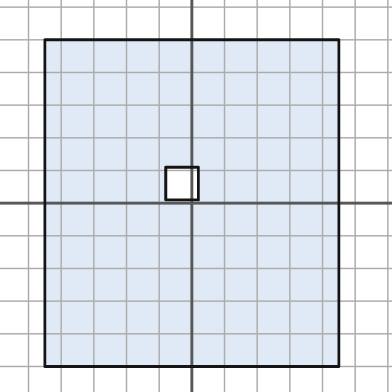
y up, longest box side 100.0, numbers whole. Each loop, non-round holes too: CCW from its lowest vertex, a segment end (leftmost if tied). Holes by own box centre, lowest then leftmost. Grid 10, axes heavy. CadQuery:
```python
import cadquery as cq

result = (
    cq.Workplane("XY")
    .moveTo(-45.0, -50.0)
    .lineTo(45.0, -50.0)
    .lineTo(45.0, 50.0)
    .lineTo(-45.0, 50.0)
    .close()
    .moveTo(-8.0, 1.0)
    .lineTo(2.0, 1.0)
    .lineTo(2.0, 11.0)
    .lineTo(-8.0, 11.0)
    .close()
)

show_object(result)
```